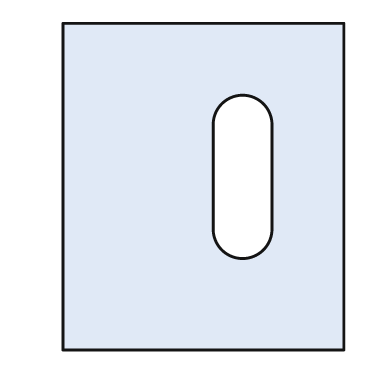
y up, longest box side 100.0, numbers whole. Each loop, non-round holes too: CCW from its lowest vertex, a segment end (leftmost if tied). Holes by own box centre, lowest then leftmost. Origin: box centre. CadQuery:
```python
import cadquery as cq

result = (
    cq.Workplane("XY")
    .moveTo(-43.0, -50.0)
    .lineTo(43.0, -50.0)
    .lineTo(43.0, 50.0)
    .lineTo(-43.0, 50.0)
    .close()
    .moveTo(3.0, -13.0)
    .threePointArc((12.0, -22.0), (21.0, -13.0))
    .lineTo(21.0, 19.0)
    .threePointArc((12.0, 28.0), (3.0, 19.0))
    .close()
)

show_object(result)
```